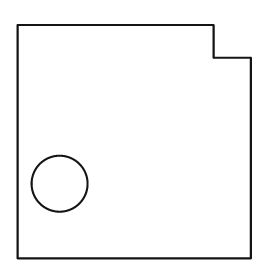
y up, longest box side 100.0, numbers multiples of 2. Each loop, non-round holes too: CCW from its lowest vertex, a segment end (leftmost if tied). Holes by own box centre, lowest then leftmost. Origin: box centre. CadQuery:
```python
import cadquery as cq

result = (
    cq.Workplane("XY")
    .moveTo(-50.0, -50.0)
    .lineTo(50.0, -50.0)
    .lineTo(50.0, 36.0)
    .lineTo(34.0, 36.0)
    .lineTo(34.0, 50.0)
    .lineTo(-50.0, 50.0)
    .close()
    .moveTo(-32.0, -18.0)
    .circle(12.0)
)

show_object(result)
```